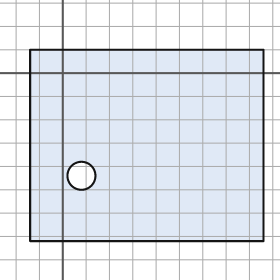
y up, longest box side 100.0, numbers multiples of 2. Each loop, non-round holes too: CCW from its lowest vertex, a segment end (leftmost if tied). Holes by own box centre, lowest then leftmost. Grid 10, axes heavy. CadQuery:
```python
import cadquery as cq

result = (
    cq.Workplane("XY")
    .moveTo(-14.0, -72.0)
    .lineTo(86.0, -72.0)
    .lineTo(86.0, 10.0)
    .lineTo(-14.0, 10.0)
    .close()
    .moveTo(8.0, -44.0)
    .circle(6.0)
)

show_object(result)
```